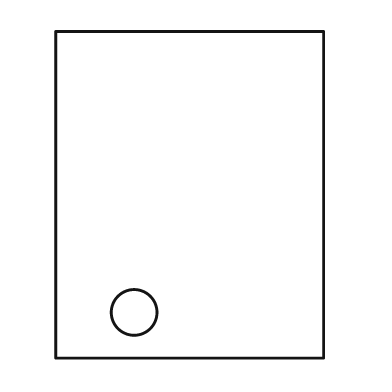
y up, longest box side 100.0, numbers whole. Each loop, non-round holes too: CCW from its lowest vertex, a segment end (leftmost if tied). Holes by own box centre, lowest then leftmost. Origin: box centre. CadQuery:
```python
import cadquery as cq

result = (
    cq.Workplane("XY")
    .moveTo(-41.0, -50.0)
    .lineTo(41.0, -50.0)
    .lineTo(41.0, 50.0)
    .lineTo(-41.0, 50.0)
    .close()
    .moveTo(-17.0, -36.0)
    .circle(7.0)
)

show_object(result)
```